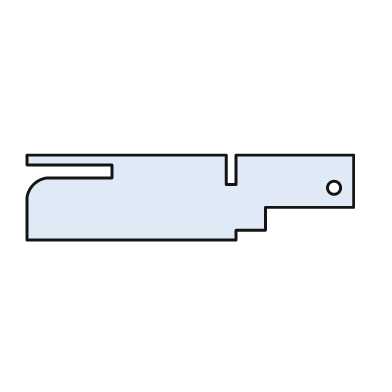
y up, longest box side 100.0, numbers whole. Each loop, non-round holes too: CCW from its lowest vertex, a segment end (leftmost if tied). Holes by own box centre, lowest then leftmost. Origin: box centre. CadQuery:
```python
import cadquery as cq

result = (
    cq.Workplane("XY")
    .moveTo(-50.0, -13.0)
    .lineTo(14.0, -13.0)
    .lineTo(14.0, -10.0)
    .lineTo(23.0, -10.0)
    .lineTo(23.0, -3.0)
    .lineTo(50.0, -3.0)
    .lineTo(50.0, 13.0)
    .lineTo(14.0, 13.0)
    .lineTo(14.0, 4.0)
    .lineTo(11.0, 4.0)
    .lineTo(11.0, 13.0)
    .lineTo(-50.0, 13.0)
    .lineTo(-50.0, 10.0)
    .lineTo(-24.0, 10.0)
    .lineTo(-24.0, 6.0)
    .lineTo(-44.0, 6.0)
    .threePointArc((-48.0, 4.0), (-50.0, 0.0))
    .close()
    .moveTo(44.0, 3.0)
    .circle(2.0)
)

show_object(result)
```